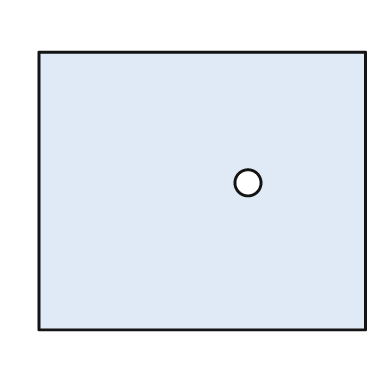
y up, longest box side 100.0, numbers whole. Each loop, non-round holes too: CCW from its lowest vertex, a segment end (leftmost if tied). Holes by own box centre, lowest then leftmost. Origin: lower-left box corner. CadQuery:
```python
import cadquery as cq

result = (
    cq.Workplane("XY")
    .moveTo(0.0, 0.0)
    .lineTo(100.0, 0.0)
    .lineTo(100.0, 85.0)
    .lineTo(0.0, 85.0)
    .close()
    .moveTo(64.0, 45.0)
    .circle(4.0)
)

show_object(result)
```